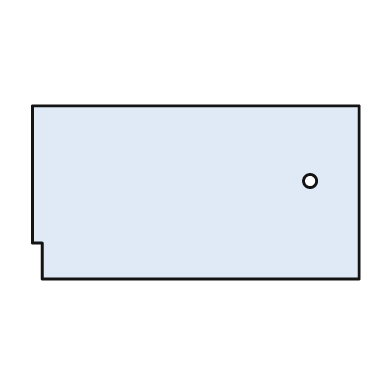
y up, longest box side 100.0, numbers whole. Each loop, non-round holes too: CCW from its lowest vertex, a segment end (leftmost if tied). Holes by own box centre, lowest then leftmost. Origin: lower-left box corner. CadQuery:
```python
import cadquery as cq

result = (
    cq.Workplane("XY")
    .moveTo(3.0, 0.0)
    .lineTo(100.0, 0.0)
    .lineTo(100.0, 53.0)
    .lineTo(0.0, 53.0)
    .lineTo(0.0, 11.0)
    .lineTo(3.0, 11.0)
    .close()
    .moveTo(85.0, 30.0)
    .circle(2.0)
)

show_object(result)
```